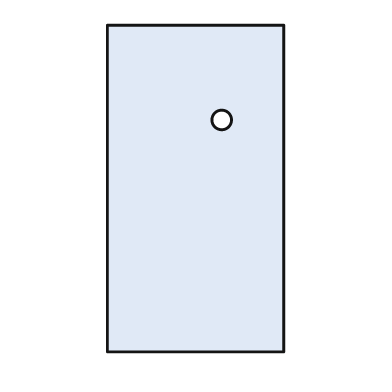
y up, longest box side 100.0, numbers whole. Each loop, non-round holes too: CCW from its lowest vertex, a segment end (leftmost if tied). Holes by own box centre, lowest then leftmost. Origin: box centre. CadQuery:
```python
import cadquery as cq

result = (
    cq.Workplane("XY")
    .moveTo(-27.0, -50.0)
    .lineTo(27.0, -50.0)
    .lineTo(27.0, 50.0)
    .lineTo(-27.0, 50.0)
    .close()
    .moveTo(8.0, 21.0)
    .circle(3.0)
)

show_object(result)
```